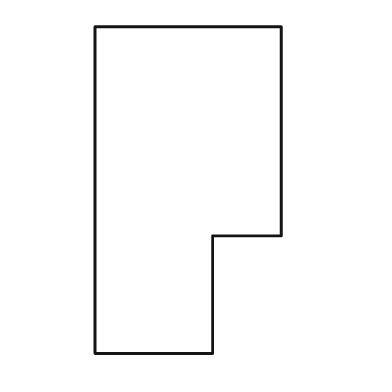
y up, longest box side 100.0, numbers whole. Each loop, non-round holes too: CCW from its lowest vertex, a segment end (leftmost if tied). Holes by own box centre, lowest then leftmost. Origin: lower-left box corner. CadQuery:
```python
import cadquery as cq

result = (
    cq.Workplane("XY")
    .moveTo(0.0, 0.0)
    .lineTo(36.0, 0.0)
    .lineTo(36.0, 36.0)
    .lineTo(57.0, 36.0)
    .lineTo(57.0, 100.0)
    .lineTo(0.0, 100.0)
    .close()
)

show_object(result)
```